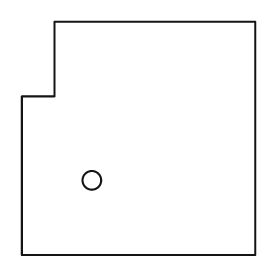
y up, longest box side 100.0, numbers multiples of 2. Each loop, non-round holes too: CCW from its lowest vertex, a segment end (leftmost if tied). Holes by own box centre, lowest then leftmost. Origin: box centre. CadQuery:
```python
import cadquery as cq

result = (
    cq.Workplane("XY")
    .moveTo(-50.0, -50.0)
    .lineTo(50.0, -50.0)
    .lineTo(50.0, 50.0)
    .lineTo(-36.0, 50.0)
    .lineTo(-36.0, 18.0)
    .lineTo(-50.0, 18.0)
    .close()
    .moveTo(-20.0, -18.0)
    .circle(4.0)
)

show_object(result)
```